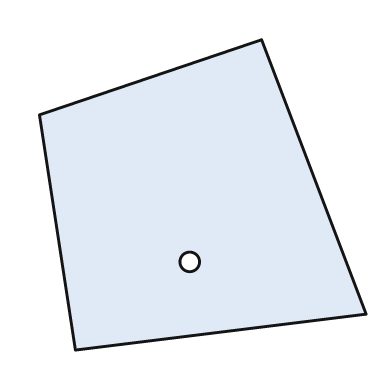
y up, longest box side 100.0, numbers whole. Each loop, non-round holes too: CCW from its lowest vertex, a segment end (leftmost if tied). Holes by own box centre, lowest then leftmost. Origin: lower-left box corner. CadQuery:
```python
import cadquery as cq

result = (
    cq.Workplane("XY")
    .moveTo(11.0, 0.0)
    .lineTo(100.0, 11.0)
    .lineTo(68.0, 95.0)
    .lineTo(0.0, 72.0)
    .close()
    .moveTo(46.0, 27.0)
    .circle(3.0)
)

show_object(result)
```